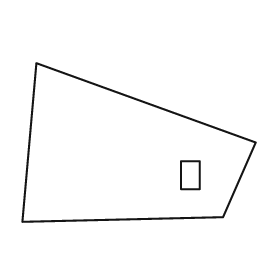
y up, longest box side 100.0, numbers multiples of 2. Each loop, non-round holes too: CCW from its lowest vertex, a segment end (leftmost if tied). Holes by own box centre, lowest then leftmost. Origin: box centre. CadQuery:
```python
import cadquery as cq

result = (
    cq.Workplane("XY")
    .moveTo(-50.0, -34.0)
    .lineTo(36.0, -32.0)
    .lineTo(50.0, 0.0)
    .lineTo(-44.0, 34.0)
    .close()
    .moveTo(18.0, -20.0)
    .lineTo(26.0, -20.0)
    .lineTo(26.0, -8.0)
    .lineTo(18.0, -8.0)
    .close()
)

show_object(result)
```